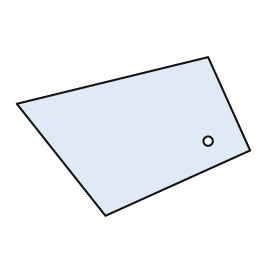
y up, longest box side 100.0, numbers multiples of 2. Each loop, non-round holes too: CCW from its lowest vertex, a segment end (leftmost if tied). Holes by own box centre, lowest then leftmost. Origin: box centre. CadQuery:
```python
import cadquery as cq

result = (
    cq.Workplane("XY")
    .moveTo(-12.0, -34.0)
    .lineTo(50.0, -6.0)
    .lineTo(32.0, 34.0)
    .lineTo(-50.0, 14.0)
    .close()
    .moveTo(32.0, -2.0)
    .circle(2.0)
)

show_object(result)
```